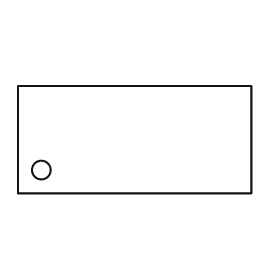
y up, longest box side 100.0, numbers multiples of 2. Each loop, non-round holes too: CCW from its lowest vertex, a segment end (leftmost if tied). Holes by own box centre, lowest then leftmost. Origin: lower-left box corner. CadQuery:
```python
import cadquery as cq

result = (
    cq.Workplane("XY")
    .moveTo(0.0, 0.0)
    .lineTo(100.0, 0.0)
    .lineTo(100.0, 46.0)
    .lineTo(0.0, 46.0)
    .close()
    .moveTo(10.0, 10.0)
    .circle(4.0)
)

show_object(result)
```